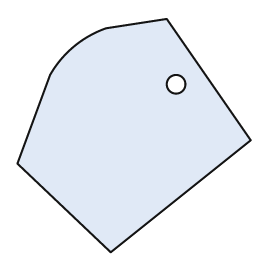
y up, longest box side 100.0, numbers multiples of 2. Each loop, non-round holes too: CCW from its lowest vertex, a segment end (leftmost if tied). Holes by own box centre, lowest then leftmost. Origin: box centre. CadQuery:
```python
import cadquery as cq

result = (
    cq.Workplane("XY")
    .moveTo(-10.0, -50.0)
    .lineTo(50.0, -2.0)
    .lineTo(14.0, 50.0)
    .lineTo(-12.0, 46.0)
    .threePointArc((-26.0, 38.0), (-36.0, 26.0))
    .lineTo(-50.0, -12.0)
    .close()
    .moveTo(18.0, 22.0)
    .circle(4.0)
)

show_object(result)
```